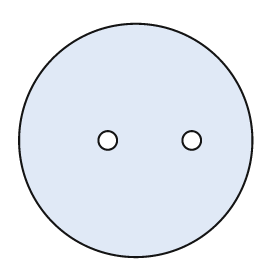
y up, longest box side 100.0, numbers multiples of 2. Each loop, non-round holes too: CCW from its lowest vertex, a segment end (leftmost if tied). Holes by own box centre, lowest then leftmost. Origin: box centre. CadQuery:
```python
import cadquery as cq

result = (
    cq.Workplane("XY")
    .moveTo(0.0, 0.0)
    .circle(50.0)
    .moveTo(-12.0, 0.0)
    .circle(4.0)
    .moveTo(24.0, 0.0)
    .circle(4.0)
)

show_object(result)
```